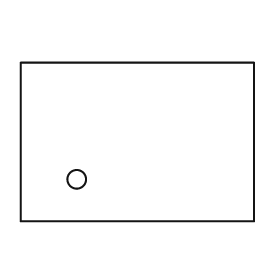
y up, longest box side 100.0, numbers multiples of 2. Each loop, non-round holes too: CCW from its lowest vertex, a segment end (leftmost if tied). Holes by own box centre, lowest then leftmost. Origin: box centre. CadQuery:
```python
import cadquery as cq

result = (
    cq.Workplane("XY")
    .moveTo(-50.0, -34.0)
    .lineTo(50.0, -34.0)
    .lineTo(50.0, 34.0)
    .lineTo(-50.0, 34.0)
    .close()
    .moveTo(-26.0, -16.0)
    .circle(4.0)
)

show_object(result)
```